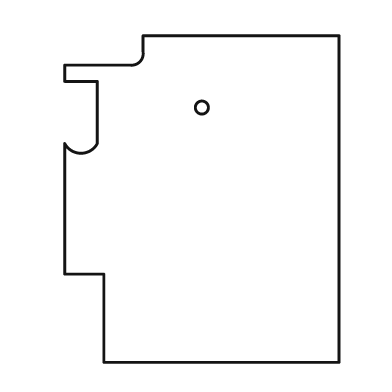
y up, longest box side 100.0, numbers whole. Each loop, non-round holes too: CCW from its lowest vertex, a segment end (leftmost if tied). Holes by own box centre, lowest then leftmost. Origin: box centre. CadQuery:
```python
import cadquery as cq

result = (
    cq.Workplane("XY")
    .moveTo(-30.0, -50.0)
    .lineTo(42.0, -50.0)
    .lineTo(42.0, 50.0)
    .lineTo(-18.0, 50.0)
    .lineTo(-18.0, 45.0)
    .threePointArc((-19.0, 42.0), (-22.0, 41.0))
    .lineTo(-42.0, 41.0)
    .lineTo(-42.0, 36.0)
    .lineTo(-32.0, 36.0)
    .lineTo(-32.0, 17.0)
    .threePointArc((-37.0, 14.0), (-42.0, 17.0))
    .lineTo(-42.0, -23.0)
    .lineTo(-30.0, -23.0)
    .close()
    .moveTo(0.0, 28.0)
    .circle(2.0)
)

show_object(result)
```